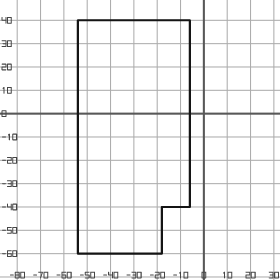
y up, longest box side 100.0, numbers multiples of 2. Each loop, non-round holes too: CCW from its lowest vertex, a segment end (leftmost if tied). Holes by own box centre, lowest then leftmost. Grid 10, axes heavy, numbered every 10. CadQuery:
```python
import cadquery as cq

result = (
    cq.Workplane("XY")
    .moveTo(-54.0, -60.0)
    .lineTo(-18.0, -60.0)
    .lineTo(-18.0, -40.0)
    .lineTo(-6.0, -40.0)
    .lineTo(-6.0, 40.0)
    .lineTo(-54.0, 40.0)
    .close()
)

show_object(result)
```